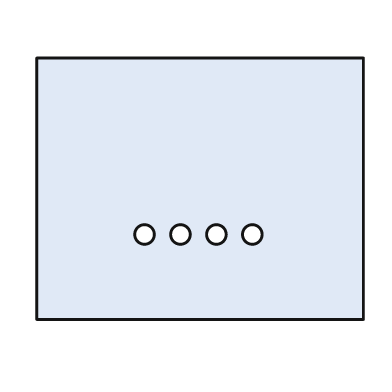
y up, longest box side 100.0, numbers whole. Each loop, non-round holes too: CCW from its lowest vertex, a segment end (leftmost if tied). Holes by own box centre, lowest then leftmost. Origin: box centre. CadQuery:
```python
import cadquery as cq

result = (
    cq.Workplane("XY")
    .moveTo(-50.0, -40.0)
    .lineTo(50.0, -40.0)
    .lineTo(50.0, 40.0)
    .lineTo(-50.0, 40.0)
    .close()
    .moveTo(-17.0, -14.0)
    .circle(3.0)
    .moveTo(-6.0, -14.0)
    .circle(3.0)
    .moveTo(5.0, -14.0)
    .circle(3.0)
    .moveTo(16.0, -14.0)
    .circle(3.0)
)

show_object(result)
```